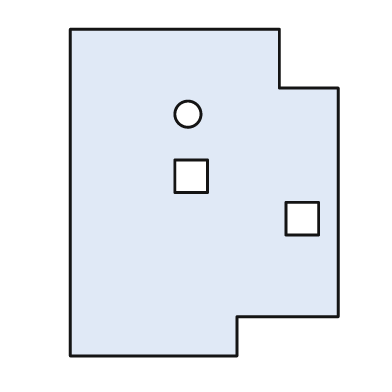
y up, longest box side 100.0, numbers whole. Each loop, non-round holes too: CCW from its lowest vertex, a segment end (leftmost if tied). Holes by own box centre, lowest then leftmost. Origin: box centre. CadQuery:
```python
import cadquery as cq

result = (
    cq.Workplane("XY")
    .moveTo(-41.0, -50.0)
    .lineTo(10.0, -50.0)
    .lineTo(10.0, -38.0)
    .lineTo(41.0, -38.0)
    .lineTo(41.0, 32.0)
    .lineTo(23.0, 32.0)
    .lineTo(23.0, 50.0)
    .lineTo(-41.0, 50.0)
    .close()
    .moveTo(25.0, -13.0)
    .lineTo(35.0, -13.0)
    .lineTo(35.0, -3.0)
    .lineTo(25.0, -3.0)
    .close()
    .moveTo(-9.0, 0.0)
    .lineTo(1.0, 0.0)
    .lineTo(1.0, 10.0)
    .lineTo(-9.0, 10.0)
    .close()
    .moveTo(-5.0, 24.0)
    .circle(4.0)
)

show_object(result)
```